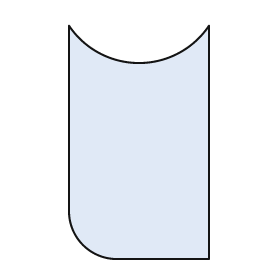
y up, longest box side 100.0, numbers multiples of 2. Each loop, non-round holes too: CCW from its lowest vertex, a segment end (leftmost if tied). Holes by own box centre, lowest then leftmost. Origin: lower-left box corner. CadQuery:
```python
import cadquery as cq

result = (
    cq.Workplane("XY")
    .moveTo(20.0, 0.0)
    .lineTo(60.0, 0.0)
    .lineTo(60.0, 100.0)
    .threePointArc((30.0, 84.0), (0.0, 100.0))
    .lineTo(0.0, 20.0)
    .threePointArc((6.0, 6.0), (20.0, 0.0))
    .close()
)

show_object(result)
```